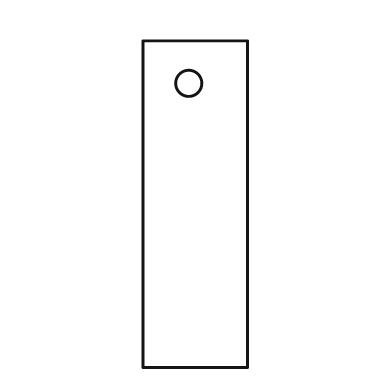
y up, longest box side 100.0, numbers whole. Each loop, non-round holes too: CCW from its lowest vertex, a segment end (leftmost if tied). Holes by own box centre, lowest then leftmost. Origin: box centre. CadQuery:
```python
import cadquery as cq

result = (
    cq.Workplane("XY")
    .moveTo(-16.0, -50.0)
    .lineTo(16.0, -50.0)
    .lineTo(16.0, 50.0)
    .lineTo(-16.0, 50.0)
    .close()
    .moveTo(-2.0, 37.0)
    .circle(4.0)
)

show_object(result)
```